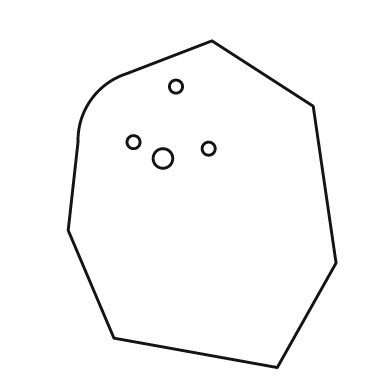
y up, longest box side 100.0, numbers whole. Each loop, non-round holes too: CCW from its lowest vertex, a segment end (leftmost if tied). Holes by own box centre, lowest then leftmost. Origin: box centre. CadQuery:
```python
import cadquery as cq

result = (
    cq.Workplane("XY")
    .moveTo(23.0, -50.0)
    .lineTo(41.0, -18.0)
    .lineTo(34.0, 30.0)
    .lineTo(3.0, 50.0)
    .lineTo(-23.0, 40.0)
    .threePointArc((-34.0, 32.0), (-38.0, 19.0))
    .lineTo(-41.0, -8.0)
    .lineTo(-27.0, -41.0)
    .close()
    .moveTo(-12.0, 14.0)
    .circle(3.0)
    .moveTo(2.0, 17.0)
    .circle(2.0)
    .moveTo(-21.0, 19.0)
    .circle(2.0)
    .moveTo(-8.0, 36.0)
    .circle(2.0)
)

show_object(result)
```